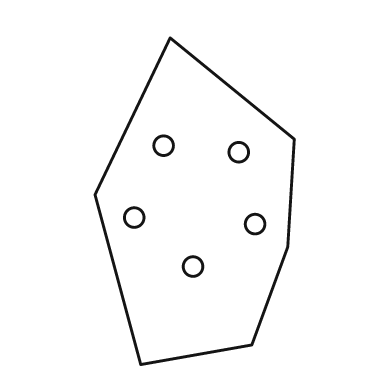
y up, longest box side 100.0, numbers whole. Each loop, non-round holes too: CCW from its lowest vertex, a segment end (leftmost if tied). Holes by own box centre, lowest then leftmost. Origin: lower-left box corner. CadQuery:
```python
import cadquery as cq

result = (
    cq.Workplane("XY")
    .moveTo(14.0, 0.0)
    .lineTo(48.0, 6.0)
    .lineTo(59.0, 36.0)
    .lineTo(61.0, 69.0)
    .lineTo(23.0, 100.0)
    .lineTo(0.0, 52.0)
    .close()
    .moveTo(30.0, 30.0)
    .circle(3.0)
    .moveTo(49.0, 43.0)
    .circle(3.0)
    .moveTo(12.0, 45.0)
    .circle(3.0)
    .moveTo(44.0, 65.0)
    .circle(3.0)
    .moveTo(21.0, 67.0)
    .circle(3.0)
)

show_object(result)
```